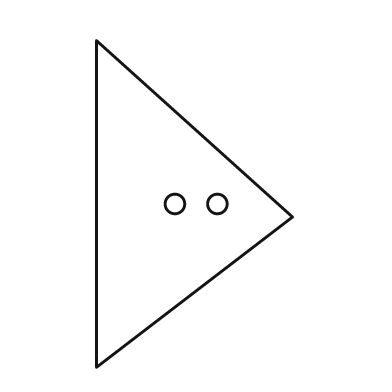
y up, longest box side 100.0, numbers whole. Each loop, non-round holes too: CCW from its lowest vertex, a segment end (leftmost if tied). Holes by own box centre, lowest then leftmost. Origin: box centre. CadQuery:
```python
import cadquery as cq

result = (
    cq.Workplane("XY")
    .moveTo(-30.0, -50.0)
    .lineTo(30.0, -4.0)
    .lineTo(-30.0, 50.0)
    .close()
    .moveTo(-6.0, 0.0)
    .circle(3.0)
    .moveTo(7.0, 0.0)
    .circle(3.0)
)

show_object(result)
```